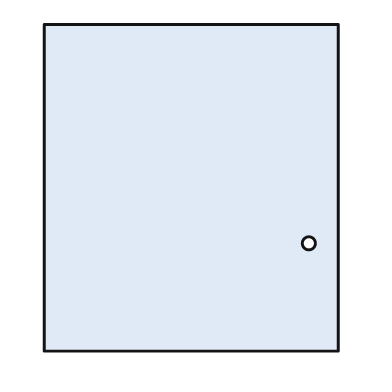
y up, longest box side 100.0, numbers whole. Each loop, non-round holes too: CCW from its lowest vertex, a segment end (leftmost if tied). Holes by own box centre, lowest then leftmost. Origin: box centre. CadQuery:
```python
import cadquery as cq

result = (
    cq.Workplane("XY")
    .moveTo(-45.0, -50.0)
    .lineTo(45.0, -50.0)
    .lineTo(45.0, 50.0)
    .lineTo(-45.0, 50.0)
    .close()
    .moveTo(36.0, -17.0)
    .circle(2.0)
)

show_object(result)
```